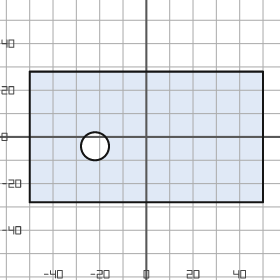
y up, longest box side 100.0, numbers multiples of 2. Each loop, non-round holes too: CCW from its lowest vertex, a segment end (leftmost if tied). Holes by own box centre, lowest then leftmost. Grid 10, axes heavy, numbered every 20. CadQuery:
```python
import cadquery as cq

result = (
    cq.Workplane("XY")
    .moveTo(-50.0, -28.0)
    .lineTo(50.0, -28.0)
    .lineTo(50.0, 28.0)
    .lineTo(-50.0, 28.0)
    .close()
    .moveTo(-22.0, -4.0)
    .circle(6.0)
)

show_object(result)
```